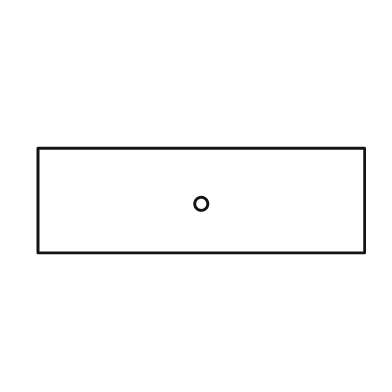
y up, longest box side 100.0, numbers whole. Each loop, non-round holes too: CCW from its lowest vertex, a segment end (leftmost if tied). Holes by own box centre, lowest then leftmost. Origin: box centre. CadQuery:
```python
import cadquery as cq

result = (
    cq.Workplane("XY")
    .moveTo(-50.0, -16.0)
    .lineTo(50.0, -16.0)
    .lineTo(50.0, 16.0)
    .lineTo(-50.0, 16.0)
    .close()
    .moveTo(0.0, -1.0)
    .circle(2.0)
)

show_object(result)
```